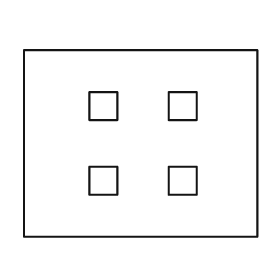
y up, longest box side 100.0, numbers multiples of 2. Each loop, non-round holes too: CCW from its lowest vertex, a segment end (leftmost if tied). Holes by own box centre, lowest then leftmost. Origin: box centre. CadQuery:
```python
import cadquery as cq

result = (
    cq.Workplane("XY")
    .moveTo(-50.0, -40.0)
    .lineTo(50.0, -40.0)
    .lineTo(50.0, 40.0)
    .lineTo(-50.0, 40.0)
    .close()
    .moveTo(-22.0, -22.0)
    .lineTo(-10.0, -22.0)
    .lineTo(-10.0, -10.0)
    .lineTo(-22.0, -10.0)
    .close()
    .moveTo(12.0, -22.0)
    .lineTo(24.0, -22.0)
    .lineTo(24.0, -10.0)
    .lineTo(12.0, -10.0)
    .close()
    .moveTo(-22.0, 10.0)
    .lineTo(-10.0, 10.0)
    .lineTo(-10.0, 22.0)
    .lineTo(-22.0, 22.0)
    .close()
    .moveTo(12.0, 10.0)
    .lineTo(24.0, 10.0)
    .lineTo(24.0, 22.0)
    .lineTo(12.0, 22.0)
    .close()
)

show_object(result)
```